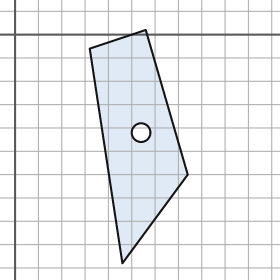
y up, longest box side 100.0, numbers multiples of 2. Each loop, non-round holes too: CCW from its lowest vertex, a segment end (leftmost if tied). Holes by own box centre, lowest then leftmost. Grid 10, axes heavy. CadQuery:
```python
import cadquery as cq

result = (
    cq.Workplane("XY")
    .moveTo(46.0, -98.0)
    .lineTo(74.0, -60.0)
    .lineTo(56.0, 2.0)
    .lineTo(32.0, -6.0)
    .close()
    .moveTo(54.0, -42.0)
    .circle(4.0)
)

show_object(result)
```